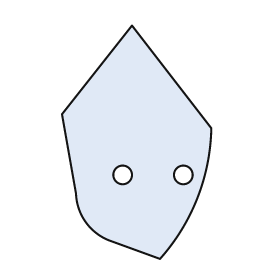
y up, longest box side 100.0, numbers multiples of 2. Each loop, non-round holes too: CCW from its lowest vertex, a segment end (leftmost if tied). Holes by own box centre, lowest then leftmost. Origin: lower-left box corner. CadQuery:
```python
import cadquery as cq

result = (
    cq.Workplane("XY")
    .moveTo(42.0, 0.0)
    .threePointArc((58.0, 26.0), (64.0, 56.0))
    .lineTo(30.0, 100.0)
    .lineTo(0.0, 62.0)
    .lineTo(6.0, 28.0)
    .threePointArc((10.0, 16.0), (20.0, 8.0))
    .close()
    .moveTo(26.0, 36.0)
    .circle(4.0)
    .moveTo(52.0, 36.0)
    .circle(4.0)
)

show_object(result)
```